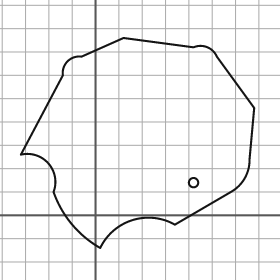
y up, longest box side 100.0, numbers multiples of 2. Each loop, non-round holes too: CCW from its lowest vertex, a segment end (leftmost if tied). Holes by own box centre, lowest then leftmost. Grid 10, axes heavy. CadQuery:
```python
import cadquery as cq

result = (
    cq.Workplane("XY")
    .moveTo(2.0, -14.0)
    .threePointArc((16.0, -2.0), (34.0, -4.0))
    .lineTo(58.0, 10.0)
    .threePointArc((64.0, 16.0), (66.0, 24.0))
    .lineTo(68.0, 46.0)
    .lineTo(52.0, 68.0)
    .threePointArc((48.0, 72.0), (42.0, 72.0))
    .lineTo(12.0, 76.0)
    .lineTo(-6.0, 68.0)
    .threePointArc((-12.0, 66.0), (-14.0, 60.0))
    .lineTo(-32.0, 26.0)
    .threePointArc((-20.0, 22.0), (-18.0, 10.0))
    .threePointArc((-10.0, -4.0), (2.0, -14.0))
    .close()
    .moveTo(42.0, 14.0)
    .circle(2.0)
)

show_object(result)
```